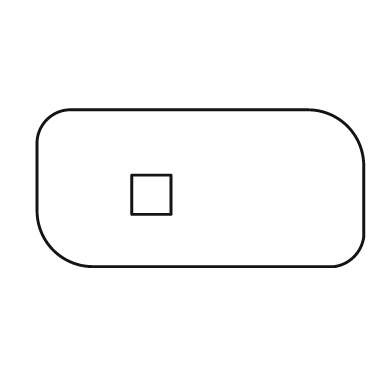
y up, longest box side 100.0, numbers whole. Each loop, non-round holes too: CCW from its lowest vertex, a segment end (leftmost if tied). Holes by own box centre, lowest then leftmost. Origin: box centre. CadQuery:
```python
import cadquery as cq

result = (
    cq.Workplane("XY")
    .moveTo(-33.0, -24.0)
    .lineTo(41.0, -24.0)
    .threePointArc((47.0, -21.0), (50.0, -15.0))
    .lineTo(50.0, 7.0)
    .threePointArc((45.0, 19.0), (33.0, 24.0))
    .lineTo(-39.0, 24.0)
    .threePointArc((-47.0, 21.0), (-50.0, 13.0))
    .lineTo(-50.0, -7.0)
    .threePointArc((-45.0, -19.0), (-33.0, -24.0))
    .close()
    .moveTo(-21.0, -8.0)
    .lineTo(-9.0, -8.0)
    .lineTo(-9.0, 4.0)
    .lineTo(-21.0, 4.0)
    .close()
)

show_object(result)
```